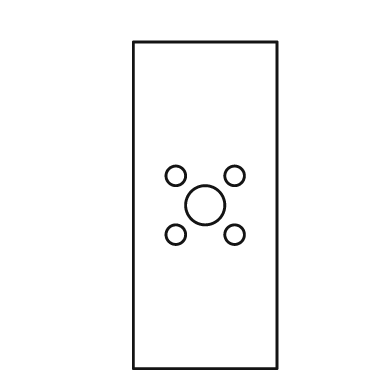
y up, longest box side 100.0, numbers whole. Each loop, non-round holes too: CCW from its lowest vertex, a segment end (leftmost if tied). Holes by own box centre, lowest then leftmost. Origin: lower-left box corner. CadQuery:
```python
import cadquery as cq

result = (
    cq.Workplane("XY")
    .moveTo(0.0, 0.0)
    .lineTo(44.0, 0.0)
    .lineTo(44.0, 100.0)
    .lineTo(0.0, 100.0)
    .close()
    .moveTo(13.0, 41.0)
    .circle(3.0)
    .moveTo(31.0, 41.0)
    .circle(3.0)
    .moveTo(22.0, 50.0)
    .circle(6.0)
    .moveTo(13.0, 59.0)
    .circle(3.0)
    .moveTo(31.0, 59.0)
    .circle(3.0)
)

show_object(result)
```